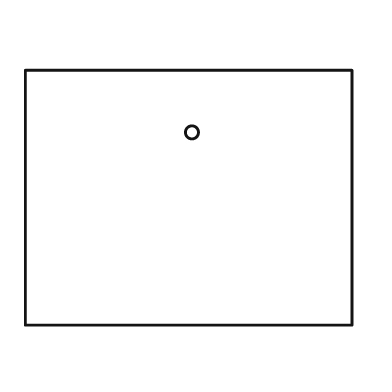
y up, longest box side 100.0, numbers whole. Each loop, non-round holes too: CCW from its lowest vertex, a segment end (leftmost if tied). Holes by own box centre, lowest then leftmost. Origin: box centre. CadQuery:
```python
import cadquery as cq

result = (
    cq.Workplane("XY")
    .moveTo(-50.0, -39.0)
    .lineTo(50.0, -39.0)
    .lineTo(50.0, 39.0)
    .lineTo(-50.0, 39.0)
    .close()
    .moveTo(1.0, 20.0)
    .circle(2.0)
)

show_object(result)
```